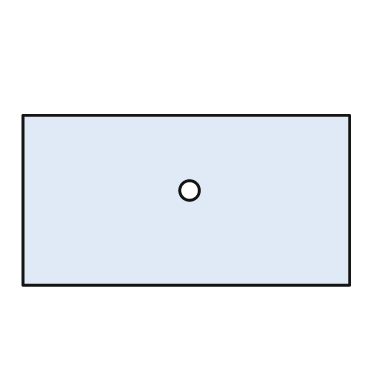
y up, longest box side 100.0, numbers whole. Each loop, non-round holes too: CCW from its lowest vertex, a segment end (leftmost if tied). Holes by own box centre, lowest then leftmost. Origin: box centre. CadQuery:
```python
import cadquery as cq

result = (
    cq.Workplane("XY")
    .moveTo(-50.0, -26.0)
    .lineTo(50.0, -26.0)
    .lineTo(50.0, 26.0)
    .lineTo(-50.0, 26.0)
    .close()
    .moveTo(1.0, 3.0)
    .circle(3.0)
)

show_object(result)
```